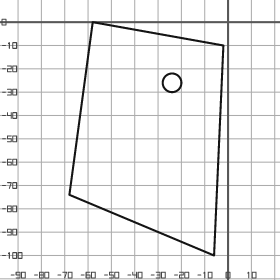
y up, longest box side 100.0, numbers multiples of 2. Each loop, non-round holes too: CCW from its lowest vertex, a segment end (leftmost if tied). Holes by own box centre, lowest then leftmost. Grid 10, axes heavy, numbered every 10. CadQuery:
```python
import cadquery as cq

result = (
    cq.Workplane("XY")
    .moveTo(-6.0, -100.0)
    .lineTo(-2.0, -10.0)
    .lineTo(-58.0, 0.0)
    .lineTo(-68.0, -74.0)
    .close()
    .moveTo(-24.0, -26.0)
    .circle(4.0)
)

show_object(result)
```